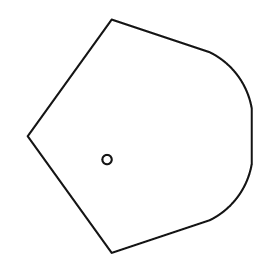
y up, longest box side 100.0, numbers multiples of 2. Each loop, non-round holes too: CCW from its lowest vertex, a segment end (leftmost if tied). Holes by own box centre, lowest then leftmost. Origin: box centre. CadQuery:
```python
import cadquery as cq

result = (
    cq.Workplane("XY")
    .moveTo(-12.0, -50.0)
    .lineTo(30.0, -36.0)
    .threePointArc((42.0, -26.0), (48.0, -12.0))
    .lineTo(48.0, 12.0)
    .threePointArc((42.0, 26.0), (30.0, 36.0))
    .lineTo(-12.0, 50.0)
    .lineTo(-48.0, 0.0)
    .close()
    .moveTo(-14.0, -10.0)
    .circle(2.0)
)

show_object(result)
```